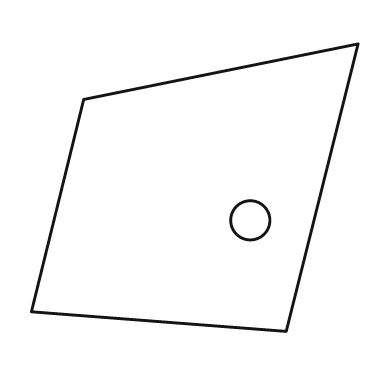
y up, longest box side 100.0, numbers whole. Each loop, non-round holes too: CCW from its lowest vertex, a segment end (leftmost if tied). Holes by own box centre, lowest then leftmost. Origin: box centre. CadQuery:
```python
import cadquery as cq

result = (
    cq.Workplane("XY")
    .moveTo(28.0, -44.0)
    .lineTo(50.0, 44.0)
    .lineTo(-34.0, 27.0)
    .lineTo(-50.0, -38.0)
    .close()
    .moveTo(17.0, -10.0)
    .circle(6.0)
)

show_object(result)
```